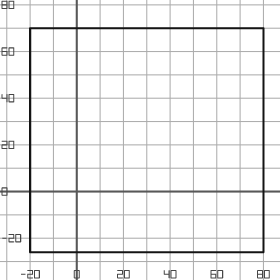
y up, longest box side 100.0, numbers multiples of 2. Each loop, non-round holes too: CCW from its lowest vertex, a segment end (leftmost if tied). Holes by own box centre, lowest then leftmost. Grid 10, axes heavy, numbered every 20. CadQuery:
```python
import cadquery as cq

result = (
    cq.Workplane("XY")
    .moveTo(-20.0, -26.0)
    .lineTo(80.0, -26.0)
    .lineTo(80.0, 70.0)
    .lineTo(-20.0, 70.0)
    .close()
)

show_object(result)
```